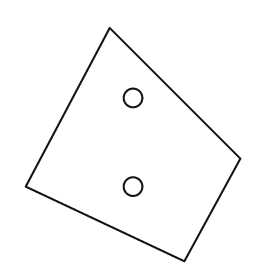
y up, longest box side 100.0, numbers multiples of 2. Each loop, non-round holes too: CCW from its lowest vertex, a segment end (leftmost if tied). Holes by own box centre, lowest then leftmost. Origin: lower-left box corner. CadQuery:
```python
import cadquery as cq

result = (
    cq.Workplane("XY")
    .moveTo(68.0, 0.0)
    .lineTo(92.0, 44.0)
    .lineTo(36.0, 100.0)
    .lineTo(0.0, 32.0)
    .close()
    .moveTo(46.0, 32.0)
    .circle(4.0)
    .moveTo(46.0, 70.0)
    .circle(4.0)
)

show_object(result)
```